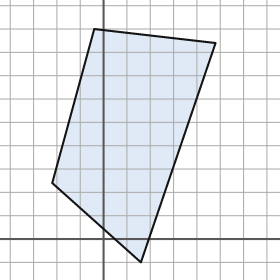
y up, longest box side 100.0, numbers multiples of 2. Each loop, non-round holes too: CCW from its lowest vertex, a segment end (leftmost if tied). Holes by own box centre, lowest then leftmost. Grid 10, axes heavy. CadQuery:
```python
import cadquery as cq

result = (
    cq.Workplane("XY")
    .moveTo(16.0, -10.0)
    .lineTo(48.0, 84.0)
    .lineTo(-4.0, 90.0)
    .lineTo(-22.0, 24.0)
    .close()
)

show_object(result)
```